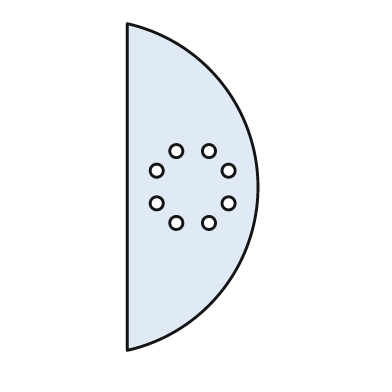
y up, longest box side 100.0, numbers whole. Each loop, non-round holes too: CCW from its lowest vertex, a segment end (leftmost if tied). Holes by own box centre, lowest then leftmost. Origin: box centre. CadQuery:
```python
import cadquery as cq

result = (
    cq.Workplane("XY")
    .moveTo(-20.0, -50.0)
    .threePointArc((20.0, 0.0), (-20.0, 50.0))
    .close()
    .moveTo(-5.0, -11.0)
    .circle(2.0)
    .moveTo(5.0, -11.0)
    .circle(2.0)
    .moveTo(-11.0, -5.0)
    .circle(2.0)
    .moveTo(11.0, -5.0)
    .circle(2.0)
    .moveTo(-11.0, 5.0)
    .circle(2.0)
    .moveTo(11.0, 5.0)
    .circle(2.0)
    .moveTo(-5.0, 11.0)
    .circle(2.0)
    .moveTo(5.0, 11.0)
    .circle(2.0)
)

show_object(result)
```